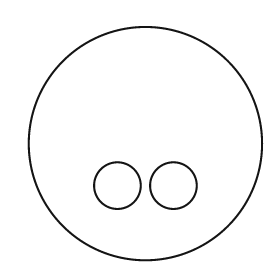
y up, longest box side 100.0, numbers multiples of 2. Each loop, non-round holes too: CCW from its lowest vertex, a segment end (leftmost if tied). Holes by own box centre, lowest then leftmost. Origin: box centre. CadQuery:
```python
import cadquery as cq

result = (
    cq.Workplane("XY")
    .moveTo(0.0, 0.0)
    .circle(50.0)
    .moveTo(-12.0, -18.0)
    .circle(10.0)
    .moveTo(12.0, -18.0)
    .circle(10.0)
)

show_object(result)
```